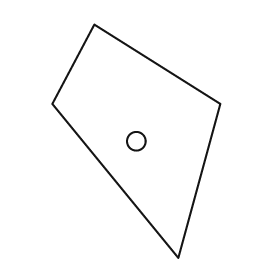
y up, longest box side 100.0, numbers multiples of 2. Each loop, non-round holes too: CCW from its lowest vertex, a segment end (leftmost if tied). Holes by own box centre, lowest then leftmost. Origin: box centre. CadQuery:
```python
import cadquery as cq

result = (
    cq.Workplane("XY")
    .moveTo(18.0, -50.0)
    .lineTo(36.0, 16.0)
    .lineTo(-18.0, 50.0)
    .lineTo(-36.0, 16.0)
    .close()
    .moveTo(0.0, 0.0)
    .circle(4.0)
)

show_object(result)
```